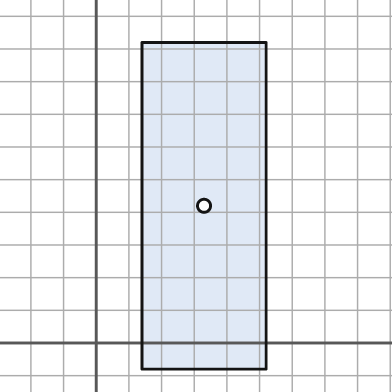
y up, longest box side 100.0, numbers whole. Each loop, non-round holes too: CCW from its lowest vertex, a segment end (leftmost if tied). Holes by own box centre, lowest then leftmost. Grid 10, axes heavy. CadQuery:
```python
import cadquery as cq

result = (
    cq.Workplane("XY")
    .moveTo(14.0, -8.0)
    .lineTo(52.0, -8.0)
    .lineTo(52.0, 92.0)
    .lineTo(14.0, 92.0)
    .close()
    .moveTo(33.0, 42.0)
    .circle(2.0)
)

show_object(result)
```